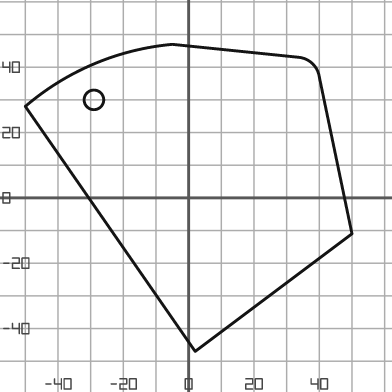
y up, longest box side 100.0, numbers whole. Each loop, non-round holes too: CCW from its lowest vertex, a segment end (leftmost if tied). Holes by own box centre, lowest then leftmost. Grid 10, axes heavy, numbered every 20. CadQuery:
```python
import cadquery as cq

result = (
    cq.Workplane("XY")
    .moveTo(2.0, -47.0)
    .lineTo(50.0, -11.0)
    .lineTo(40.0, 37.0)
    .threePointArc((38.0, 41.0), (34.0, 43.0))
    .lineTo(-5.0, 47.0)
    .threePointArc((-29.0, 41.0), (-50.0, 28.0))
    .close()
    .moveTo(-29.0, 30.0)
    .circle(3.0)
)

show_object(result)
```